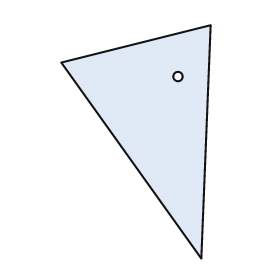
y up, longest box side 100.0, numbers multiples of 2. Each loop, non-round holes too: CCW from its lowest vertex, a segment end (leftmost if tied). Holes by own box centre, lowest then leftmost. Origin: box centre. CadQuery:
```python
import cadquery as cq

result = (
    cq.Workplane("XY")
    .moveTo(28.0, -50.0)
    .lineTo(32.0, 50.0)
    .lineTo(-32.0, 34.0)
    .close()
    .moveTo(18.0, 28.0)
    .circle(2.0)
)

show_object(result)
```